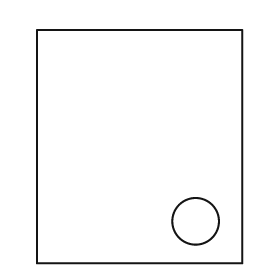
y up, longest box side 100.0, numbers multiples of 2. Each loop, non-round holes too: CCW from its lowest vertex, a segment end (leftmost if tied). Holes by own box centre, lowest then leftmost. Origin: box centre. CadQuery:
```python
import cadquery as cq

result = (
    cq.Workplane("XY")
    .moveTo(-44.0, -50.0)
    .lineTo(44.0, -50.0)
    .lineTo(44.0, 50.0)
    .lineTo(-44.0, 50.0)
    .close()
    .moveTo(24.0, -32.0)
    .circle(10.0)
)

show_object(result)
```